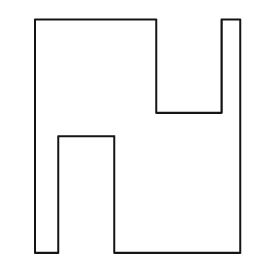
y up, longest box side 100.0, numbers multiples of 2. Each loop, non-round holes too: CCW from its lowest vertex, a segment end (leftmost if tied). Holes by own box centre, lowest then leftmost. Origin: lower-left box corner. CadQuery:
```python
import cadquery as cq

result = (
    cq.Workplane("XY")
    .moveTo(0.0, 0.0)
    .lineTo(10.0, 0.0)
    .lineTo(10.0, 50.0)
    .lineTo(34.0, 50.0)
    .lineTo(34.0, 0.0)
    .lineTo(88.0, 0.0)
    .lineTo(88.0, 100.0)
    .lineTo(80.0, 100.0)
    .lineTo(80.0, 60.0)
    .lineTo(52.0, 60.0)
    .lineTo(52.0, 100.0)
    .lineTo(0.0, 100.0)
    .close()
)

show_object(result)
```